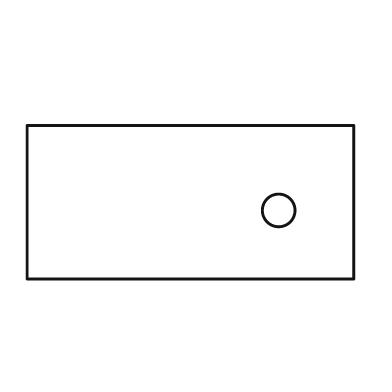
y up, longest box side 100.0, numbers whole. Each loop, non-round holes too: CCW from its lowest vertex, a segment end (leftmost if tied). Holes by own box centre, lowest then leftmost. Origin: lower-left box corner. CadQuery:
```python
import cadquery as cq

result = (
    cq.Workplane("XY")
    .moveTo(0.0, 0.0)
    .lineTo(100.0, 0.0)
    .lineTo(100.0, 47.0)
    .lineTo(0.0, 47.0)
    .close()
    .moveTo(77.0, 21.0)
    .circle(5.0)
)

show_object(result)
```